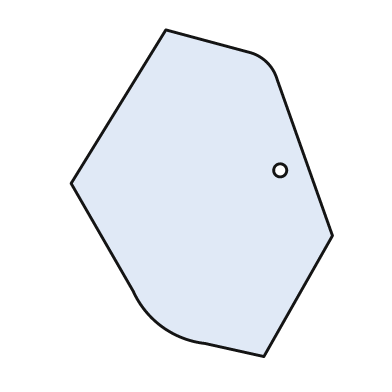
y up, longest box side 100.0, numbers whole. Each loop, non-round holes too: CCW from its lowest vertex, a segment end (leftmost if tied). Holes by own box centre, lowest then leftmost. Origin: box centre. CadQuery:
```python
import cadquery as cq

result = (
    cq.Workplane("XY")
    .moveTo(19.0, -50.0)
    .lineTo(40.0, -13.0)
    .lineTo(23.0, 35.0)
    .threePointArc((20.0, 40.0), (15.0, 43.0))
    .lineTo(-11.0, 50.0)
    .lineTo(-40.0, 3.0)
    .lineTo(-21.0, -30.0)
    .threePointArc((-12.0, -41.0), (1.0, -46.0))
    .close()
    .moveTo(24.0, 7.0)
    .circle(2.0)
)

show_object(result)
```